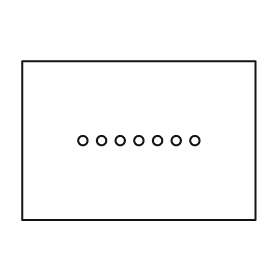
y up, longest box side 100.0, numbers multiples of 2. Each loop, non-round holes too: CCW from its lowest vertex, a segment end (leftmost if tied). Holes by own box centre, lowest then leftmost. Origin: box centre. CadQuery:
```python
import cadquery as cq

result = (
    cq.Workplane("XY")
    .moveTo(-50.0, -34.0)
    .lineTo(50.0, -34.0)
    .lineTo(50.0, 34.0)
    .lineTo(-50.0, 34.0)
    .close()
    .moveTo(-24.0, 0.0)
    .circle(2.0)
    .moveTo(-16.0, 0.0)
    .circle(2.0)
    .moveTo(-8.0, 0.0)
    .circle(2.0)
    .moveTo(0.0, 0.0)
    .circle(2.0)
    .moveTo(8.0, 0.0)
    .circle(2.0)
    .moveTo(16.0, 0.0)
    .circle(2.0)
    .moveTo(24.0, 0.0)
    .circle(2.0)
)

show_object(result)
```